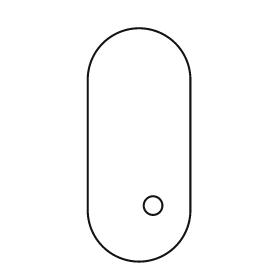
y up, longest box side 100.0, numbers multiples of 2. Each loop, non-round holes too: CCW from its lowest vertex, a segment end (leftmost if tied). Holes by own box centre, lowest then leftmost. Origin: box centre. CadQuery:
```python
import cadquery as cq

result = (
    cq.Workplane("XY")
    .moveTo(-22.0, -28.0)
    .threePointArc((0.0, -50.0), (22.0, -28.0))
    .lineTo(22.0, 28.0)
    .threePointArc((0.0, 50.0), (-22.0, 28.0))
    .close()
    .moveTo(6.0, -26.0)
    .circle(4.0)
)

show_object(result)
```